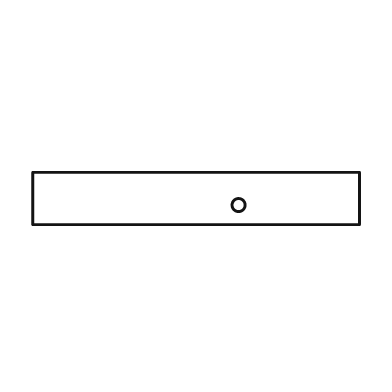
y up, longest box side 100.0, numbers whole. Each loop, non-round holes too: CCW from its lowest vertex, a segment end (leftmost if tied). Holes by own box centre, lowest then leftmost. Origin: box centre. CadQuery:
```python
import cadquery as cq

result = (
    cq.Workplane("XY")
    .moveTo(-50.0, -8.0)
    .lineTo(50.0, -8.0)
    .lineTo(50.0, 8.0)
    .lineTo(-50.0, 8.0)
    .close()
    .moveTo(13.0, -2.0)
    .circle(2.0)
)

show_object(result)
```